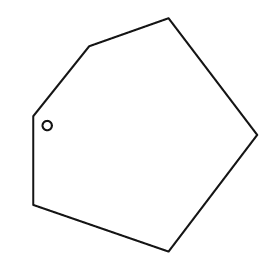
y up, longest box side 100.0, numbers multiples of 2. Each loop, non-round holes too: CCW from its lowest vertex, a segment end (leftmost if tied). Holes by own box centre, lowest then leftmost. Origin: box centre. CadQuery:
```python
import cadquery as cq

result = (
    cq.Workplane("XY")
    .moveTo(10.0, -50.0)
    .lineTo(48.0, 0.0)
    .lineTo(10.0, 50.0)
    .lineTo(-24.0, 38.0)
    .lineTo(-48.0, 8.0)
    .lineTo(-48.0, -30.0)
    .close()
    .moveTo(-42.0, 4.0)
    .circle(2.0)
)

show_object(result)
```